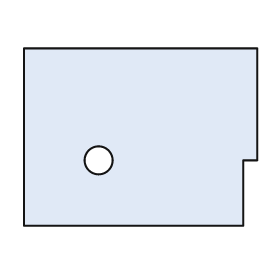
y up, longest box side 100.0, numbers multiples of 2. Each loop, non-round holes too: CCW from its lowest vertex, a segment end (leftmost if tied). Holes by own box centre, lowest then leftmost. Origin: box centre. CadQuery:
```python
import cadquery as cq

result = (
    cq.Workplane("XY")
    .moveTo(-50.0, -38.0)
    .lineTo(44.0, -38.0)
    .lineTo(44.0, -10.0)
    .lineTo(50.0, -10.0)
    .lineTo(50.0, 38.0)
    .lineTo(-50.0, 38.0)
    .close()
    .moveTo(-18.0, -10.0)
    .circle(6.0)
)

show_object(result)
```